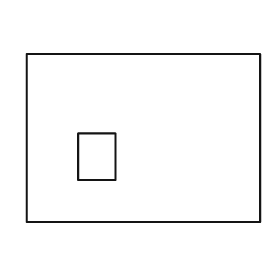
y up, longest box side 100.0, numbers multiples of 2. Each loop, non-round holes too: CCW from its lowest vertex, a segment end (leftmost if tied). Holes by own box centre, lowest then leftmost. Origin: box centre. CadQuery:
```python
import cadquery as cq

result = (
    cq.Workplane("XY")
    .moveTo(-50.0, -36.0)
    .lineTo(50.0, -36.0)
    .lineTo(50.0, 36.0)
    .lineTo(-50.0, 36.0)
    .close()
    .moveTo(-28.0, -18.0)
    .lineTo(-12.0, -18.0)
    .lineTo(-12.0, 2.0)
    .lineTo(-28.0, 2.0)
    .close()
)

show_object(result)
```